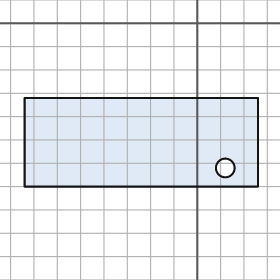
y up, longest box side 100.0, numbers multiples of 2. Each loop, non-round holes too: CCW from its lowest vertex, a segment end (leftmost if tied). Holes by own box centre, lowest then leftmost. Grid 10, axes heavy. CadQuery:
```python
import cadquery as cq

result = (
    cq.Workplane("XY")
    .moveTo(-74.0, -70.0)
    .lineTo(26.0, -70.0)
    .lineTo(26.0, -32.0)
    .lineTo(-74.0, -32.0)
    .close()
    .moveTo(12.0, -62.0)
    .circle(4.0)
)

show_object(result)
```